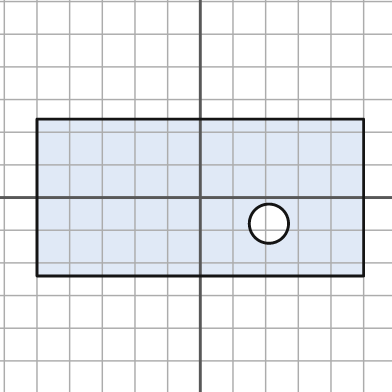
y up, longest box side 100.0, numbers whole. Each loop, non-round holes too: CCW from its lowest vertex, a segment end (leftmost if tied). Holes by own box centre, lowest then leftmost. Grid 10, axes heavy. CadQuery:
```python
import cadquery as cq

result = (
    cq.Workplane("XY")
    .moveTo(-50.0, -24.0)
    .lineTo(50.0, -24.0)
    .lineTo(50.0, 24.0)
    .lineTo(-50.0, 24.0)
    .close()
    .moveTo(21.0, -8.0)
    .circle(6.0)
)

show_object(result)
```